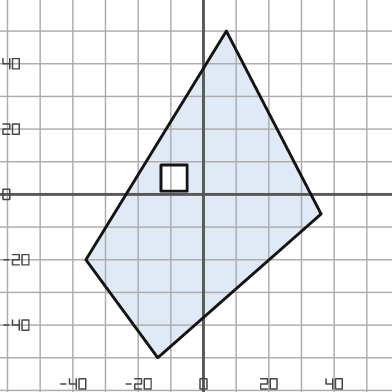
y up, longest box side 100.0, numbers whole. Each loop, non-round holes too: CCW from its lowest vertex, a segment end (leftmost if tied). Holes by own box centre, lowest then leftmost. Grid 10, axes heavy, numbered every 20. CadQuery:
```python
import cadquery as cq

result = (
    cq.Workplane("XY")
    .moveTo(-14.0, -50.0)
    .lineTo(36.0, -6.0)
    .lineTo(7.0, 50.0)
    .lineTo(-36.0, -20.0)
    .close()
    .moveTo(-13.0, 1.0)
    .lineTo(-5.0, 1.0)
    .lineTo(-5.0, 9.0)
    .lineTo(-13.0, 9.0)
    .close()
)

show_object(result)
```